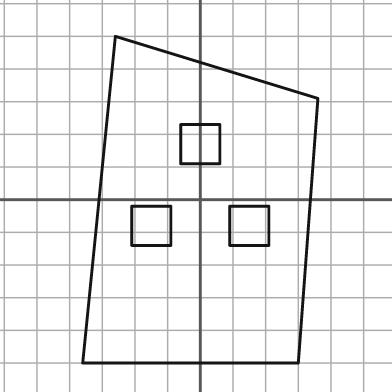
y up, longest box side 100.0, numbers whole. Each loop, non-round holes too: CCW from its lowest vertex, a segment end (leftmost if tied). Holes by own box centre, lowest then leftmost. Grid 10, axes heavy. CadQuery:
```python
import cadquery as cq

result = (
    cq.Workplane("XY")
    .moveTo(-36.0, -50.0)
    .lineTo(30.0, -50.0)
    .lineTo(36.0, 31.0)
    .lineTo(-26.0, 50.0)
    .close()
    .moveTo(-21.0, -14.0)
    .lineTo(-9.0, -14.0)
    .lineTo(-9.0, -2.0)
    .lineTo(-21.0, -2.0)
    .close()
    .moveTo(9.0, -14.0)
    .lineTo(21.0, -14.0)
    .lineTo(21.0, -2.0)
    .lineTo(9.0, -2.0)
    .close()
    .moveTo(-6.0, 11.0)
    .lineTo(6.0, 11.0)
    .lineTo(6.0, 23.0)
    .lineTo(-6.0, 23.0)
    .close()
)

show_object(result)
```